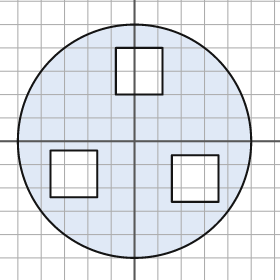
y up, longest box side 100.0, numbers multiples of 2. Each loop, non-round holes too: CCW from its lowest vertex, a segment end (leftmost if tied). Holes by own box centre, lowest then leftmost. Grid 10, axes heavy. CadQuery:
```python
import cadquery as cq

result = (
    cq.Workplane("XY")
    .moveTo(0.0, 0.0)
    .circle(50.0)
    .moveTo(16.0, -26.0)
    .lineTo(36.0, -26.0)
    .lineTo(36.0, -6.0)
    .lineTo(16.0, -6.0)
    .close()
    .moveTo(-36.0, -24.0)
    .lineTo(-16.0, -24.0)
    .lineTo(-16.0, -4.0)
    .lineTo(-36.0, -4.0)
    .close()
    .moveTo(-8.0, 20.0)
    .lineTo(12.0, 20.0)
    .lineTo(12.0, 40.0)
    .lineTo(-8.0, 40.0)
    .close()
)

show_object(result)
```